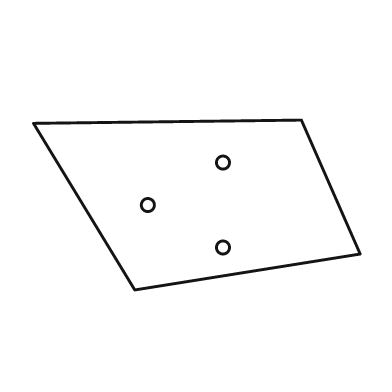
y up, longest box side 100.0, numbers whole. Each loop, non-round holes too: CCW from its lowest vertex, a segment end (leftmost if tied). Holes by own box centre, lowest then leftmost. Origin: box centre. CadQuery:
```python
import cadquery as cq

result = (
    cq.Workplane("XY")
    .moveTo(-19.0, -26.0)
    .lineTo(50.0, -15.0)
    .lineTo(32.0, 26.0)
    .lineTo(-50.0, 25.0)
    .close()
    .moveTo(8.0, -13.0)
    .circle(2.0)
    .moveTo(-15.0, 0.0)
    .circle(2.0)
    .moveTo(8.0, 13.0)
    .circle(2.0)
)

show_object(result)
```